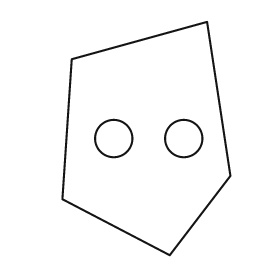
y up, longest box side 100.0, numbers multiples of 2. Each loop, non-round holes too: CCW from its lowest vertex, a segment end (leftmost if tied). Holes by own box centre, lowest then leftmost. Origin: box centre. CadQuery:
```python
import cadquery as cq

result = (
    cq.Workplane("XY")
    .moveTo(10.0, -50.0)
    .lineTo(36.0, -16.0)
    .lineTo(26.0, 50.0)
    .lineTo(-32.0, 34.0)
    .lineTo(-36.0, -26.0)
    .close()
    .moveTo(-14.0, 0.0)
    .circle(8.0)
    .moveTo(16.0, 0.0)
    .circle(8.0)
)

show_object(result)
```